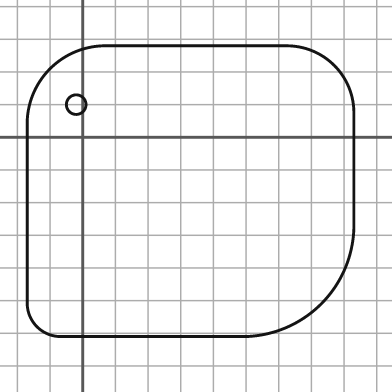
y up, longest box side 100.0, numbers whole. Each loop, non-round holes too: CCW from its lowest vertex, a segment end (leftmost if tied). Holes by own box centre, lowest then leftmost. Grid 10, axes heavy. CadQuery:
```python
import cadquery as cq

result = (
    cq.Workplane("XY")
    .moveTo(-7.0, -61.0)
    .lineTo(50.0, -61.0)
    .threePointArc((73.0, -51.0), (83.0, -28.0))
    .lineTo(83.0, 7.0)
    .threePointArc((77.0, 22.0), (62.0, 28.0))
    .lineTo(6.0, 28.0)
    .threePointArc((-10.0, 21.0), (-17.0, 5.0))
    .lineTo(-17.0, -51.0)
    .threePointArc((-14.0, -58.0), (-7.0, -61.0))
    .close()
    .moveTo(-2.0, 10.0)
    .circle(3.0)
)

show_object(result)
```